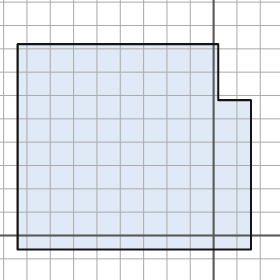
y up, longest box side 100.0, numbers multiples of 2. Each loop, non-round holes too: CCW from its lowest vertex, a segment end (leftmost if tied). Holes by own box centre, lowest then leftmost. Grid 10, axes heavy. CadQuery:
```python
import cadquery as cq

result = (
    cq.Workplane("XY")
    .moveTo(-84.0, -6.0)
    .lineTo(16.0, -6.0)
    .lineTo(16.0, 58.0)
    .lineTo(2.0, 58.0)
    .lineTo(2.0, 82.0)
    .lineTo(-84.0, 82.0)
    .close()
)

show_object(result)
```